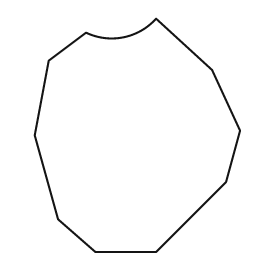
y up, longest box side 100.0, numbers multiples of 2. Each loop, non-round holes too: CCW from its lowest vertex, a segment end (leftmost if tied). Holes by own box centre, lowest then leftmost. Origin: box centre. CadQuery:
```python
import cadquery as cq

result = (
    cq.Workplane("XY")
    .moveTo(-18.0, -50.0)
    .lineTo(8.0, -50.0)
    .lineTo(38.0, -20.0)
    .lineTo(44.0, 2.0)
    .lineTo(32.0, 28.0)
    .lineTo(8.0, 50.0)
    .threePointArc((-6.0, 42.0), (-22.0, 44.0))
    .lineTo(-38.0, 32.0)
    .lineTo(-44.0, 0.0)
    .lineTo(-34.0, -36.0)
    .close()
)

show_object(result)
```